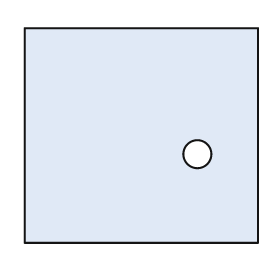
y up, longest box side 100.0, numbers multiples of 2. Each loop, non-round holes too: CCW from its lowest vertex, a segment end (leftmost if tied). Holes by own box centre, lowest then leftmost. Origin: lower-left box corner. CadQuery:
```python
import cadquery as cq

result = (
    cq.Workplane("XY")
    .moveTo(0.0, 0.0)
    .lineTo(100.0, 0.0)
    .lineTo(100.0, 92.0)
    .lineTo(0.0, 92.0)
    .close()
    .moveTo(74.0, 38.0)
    .circle(6.0)
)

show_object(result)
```